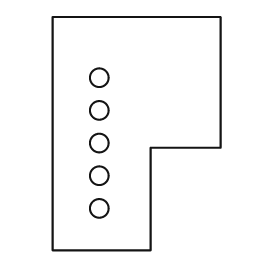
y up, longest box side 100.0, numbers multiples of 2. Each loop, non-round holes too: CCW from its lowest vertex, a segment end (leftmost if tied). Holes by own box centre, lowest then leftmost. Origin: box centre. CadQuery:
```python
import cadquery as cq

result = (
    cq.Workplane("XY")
    .moveTo(-36.0, -50.0)
    .lineTo(6.0, -50.0)
    .lineTo(6.0, -6.0)
    .lineTo(36.0, -6.0)
    .lineTo(36.0, 50.0)
    .lineTo(-36.0, 50.0)
    .close()
    .moveTo(-16.0, -32.0)
    .circle(4.0)
    .moveTo(-16.0, -18.0)
    .circle(4.0)
    .moveTo(-16.0, -4.0)
    .circle(4.0)
    .moveTo(-16.0, 10.0)
    .circle(4.0)
    .moveTo(-16.0, 24.0)
    .circle(4.0)
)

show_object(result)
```